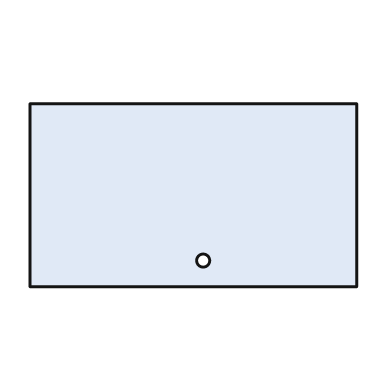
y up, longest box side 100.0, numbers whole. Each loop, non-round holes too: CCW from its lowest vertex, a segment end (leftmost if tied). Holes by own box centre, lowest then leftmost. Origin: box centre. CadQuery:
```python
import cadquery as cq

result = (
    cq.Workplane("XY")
    .moveTo(-50.0, -28.0)
    .lineTo(50.0, -28.0)
    .lineTo(50.0, 28.0)
    .lineTo(-50.0, 28.0)
    .close()
    .moveTo(3.0, -20.0)
    .circle(2.0)
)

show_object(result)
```